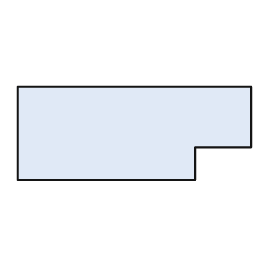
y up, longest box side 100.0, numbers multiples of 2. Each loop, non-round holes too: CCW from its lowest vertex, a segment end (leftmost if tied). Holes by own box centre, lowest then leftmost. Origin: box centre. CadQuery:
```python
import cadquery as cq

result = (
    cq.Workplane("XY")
    .moveTo(-50.0, -20.0)
    .lineTo(26.0, -20.0)
    .lineTo(26.0, -6.0)
    .lineTo(50.0, -6.0)
    .lineTo(50.0, 20.0)
    .lineTo(-50.0, 20.0)
    .close()
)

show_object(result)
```